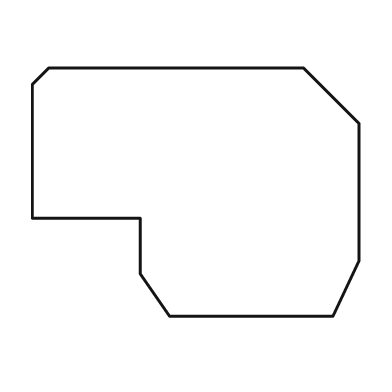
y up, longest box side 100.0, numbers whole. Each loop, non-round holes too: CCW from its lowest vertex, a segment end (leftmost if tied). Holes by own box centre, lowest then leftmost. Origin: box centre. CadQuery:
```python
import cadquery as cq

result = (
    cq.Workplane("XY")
    .moveTo(-8.0, -38.0)
    .lineTo(42.0, -38.0)
    .lineTo(50.0, -21.0)
    .lineTo(50.0, 21.0)
    .lineTo(33.0, 38.0)
    .lineTo(-45.0, 38.0)
    .lineTo(-50.0, 33.0)
    .lineTo(-50.0, -8.0)
    .lineTo(-17.0, -8.0)
    .lineTo(-17.0, -25.0)
    .close()
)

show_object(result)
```